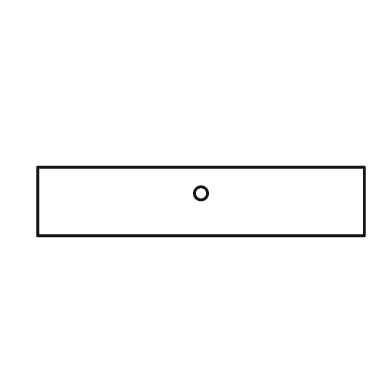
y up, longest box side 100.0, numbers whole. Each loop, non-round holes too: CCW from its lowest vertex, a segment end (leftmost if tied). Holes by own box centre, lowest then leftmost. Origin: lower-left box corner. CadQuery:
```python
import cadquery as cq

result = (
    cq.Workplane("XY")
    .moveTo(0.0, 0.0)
    .lineTo(100.0, 0.0)
    .lineTo(100.0, 21.0)
    .lineTo(0.0, 21.0)
    .close()
    .moveTo(50.0, 13.0)
    .circle(2.0)
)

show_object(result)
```